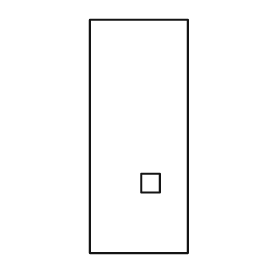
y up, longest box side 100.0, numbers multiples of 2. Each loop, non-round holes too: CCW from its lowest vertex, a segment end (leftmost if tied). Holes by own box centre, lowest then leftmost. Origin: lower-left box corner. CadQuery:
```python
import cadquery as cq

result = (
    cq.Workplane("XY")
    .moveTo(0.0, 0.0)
    .lineTo(42.0, 0.0)
    .lineTo(42.0, 100.0)
    .lineTo(0.0, 100.0)
    .close()
    .moveTo(22.0, 26.0)
    .lineTo(30.0, 26.0)
    .lineTo(30.0, 34.0)
    .lineTo(22.0, 34.0)
    .close()
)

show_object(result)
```